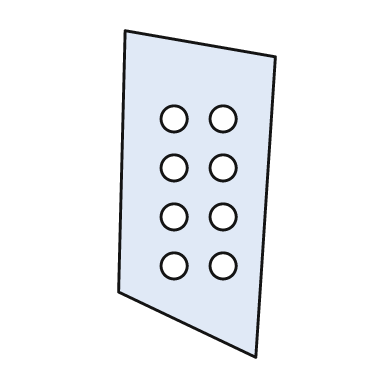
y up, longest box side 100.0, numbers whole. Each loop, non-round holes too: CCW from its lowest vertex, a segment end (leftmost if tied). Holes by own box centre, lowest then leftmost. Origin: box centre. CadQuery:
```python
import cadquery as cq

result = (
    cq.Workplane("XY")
    .moveTo(18.0, -50.0)
    .lineTo(24.0, 42.0)
    .lineTo(-22.0, 50.0)
    .lineTo(-24.0, -30.0)
    .close()
    .moveTo(-7.0, -22.0)
    .circle(4.0)
    .moveTo(8.0, -22.0)
    .circle(4.0)
    .moveTo(-7.0, -7.0)
    .circle(4.0)
    .moveTo(8.0, -7.0)
    .circle(4.0)
    .moveTo(-7.0, 8.0)
    .circle(4.0)
    .moveTo(8.0, 8.0)
    .circle(4.0)
    .moveTo(-7.0, 23.0)
    .circle(4.0)
    .moveTo(8.0, 23.0)
    .circle(4.0)
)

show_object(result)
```